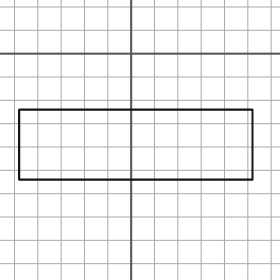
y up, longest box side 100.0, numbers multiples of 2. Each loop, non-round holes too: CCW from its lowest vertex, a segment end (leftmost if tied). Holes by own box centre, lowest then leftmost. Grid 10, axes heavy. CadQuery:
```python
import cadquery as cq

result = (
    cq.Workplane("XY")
    .moveTo(-48.0, -54.0)
    .lineTo(52.0, -54.0)
    .lineTo(52.0, -24.0)
    .lineTo(-48.0, -24.0)
    .close()
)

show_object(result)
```